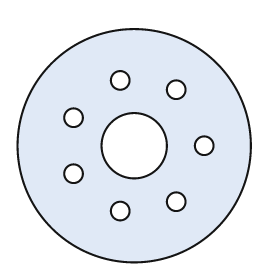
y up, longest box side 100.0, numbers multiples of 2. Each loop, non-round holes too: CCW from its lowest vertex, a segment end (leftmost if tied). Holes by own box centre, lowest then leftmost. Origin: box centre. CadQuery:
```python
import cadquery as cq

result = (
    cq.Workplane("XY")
    .moveTo(0.0, 0.0)
    .circle(50.0)
    .moveTo(-6.0, -28.0)
    .circle(4.0)
    .moveTo(18.0, -24.0)
    .circle(4.0)
    .moveTo(-26.0, -12.0)
    .circle(4.0)
    .moveTo(0.0, 0.0)
    .circle(14.0)
    .moveTo(30.0, 0.0)
    .circle(4.0)
    .moveTo(-26.0, 12.0)
    .circle(4.0)
    .moveTo(18.0, 24.0)
    .circle(4.0)
    .moveTo(-6.0, 28.0)
    .circle(4.0)
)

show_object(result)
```